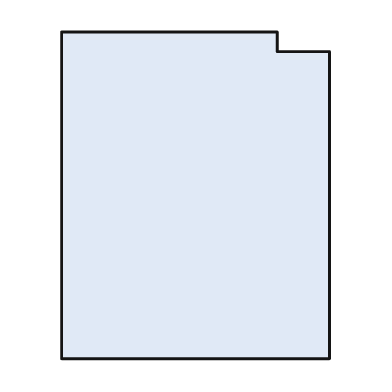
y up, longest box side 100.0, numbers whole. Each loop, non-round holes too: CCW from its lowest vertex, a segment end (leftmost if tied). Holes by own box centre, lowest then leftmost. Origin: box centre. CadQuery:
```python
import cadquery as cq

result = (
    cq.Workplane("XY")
    .moveTo(-41.0, -50.0)
    .lineTo(41.0, -50.0)
    .lineTo(41.0, 44.0)
    .lineTo(25.0, 44.0)
    .lineTo(25.0, 50.0)
    .lineTo(-41.0, 50.0)
    .close()
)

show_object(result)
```